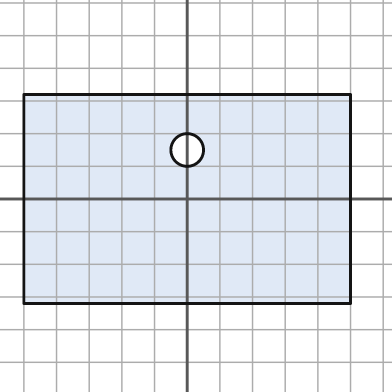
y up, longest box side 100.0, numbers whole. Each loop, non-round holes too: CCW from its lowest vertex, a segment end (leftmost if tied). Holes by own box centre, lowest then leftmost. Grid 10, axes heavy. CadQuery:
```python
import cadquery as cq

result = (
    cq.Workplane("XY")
    .moveTo(-50.0, -32.0)
    .lineTo(50.0, -32.0)
    .lineTo(50.0, 32.0)
    .lineTo(-50.0, 32.0)
    .close()
    .moveTo(0.0, 15.0)
    .circle(5.0)
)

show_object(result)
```